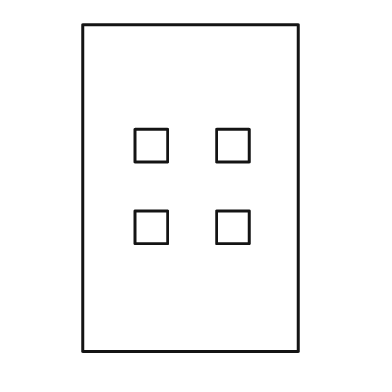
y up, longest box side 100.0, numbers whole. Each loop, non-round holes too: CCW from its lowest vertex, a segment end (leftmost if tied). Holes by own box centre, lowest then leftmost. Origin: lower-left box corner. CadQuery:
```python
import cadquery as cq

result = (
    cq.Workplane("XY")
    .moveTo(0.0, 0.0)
    .lineTo(66.0, 0.0)
    .lineTo(66.0, 100.0)
    .lineTo(0.0, 100.0)
    .close()
    .moveTo(16.0, 33.0)
    .lineTo(26.0, 33.0)
    .lineTo(26.0, 43.0)
    .lineTo(16.0, 43.0)
    .close()
    .moveTo(41.0, 33.0)
    .lineTo(51.0, 33.0)
    .lineTo(51.0, 43.0)
    .lineTo(41.0, 43.0)
    .close()
    .moveTo(16.0, 58.0)
    .lineTo(26.0, 58.0)
    .lineTo(26.0, 68.0)
    .lineTo(16.0, 68.0)
    .close()
    .moveTo(41.0, 58.0)
    .lineTo(51.0, 58.0)
    .lineTo(51.0, 68.0)
    .lineTo(41.0, 68.0)
    .close()
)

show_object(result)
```